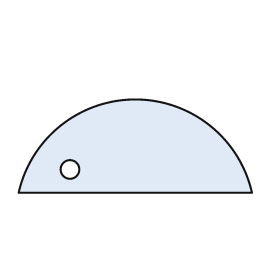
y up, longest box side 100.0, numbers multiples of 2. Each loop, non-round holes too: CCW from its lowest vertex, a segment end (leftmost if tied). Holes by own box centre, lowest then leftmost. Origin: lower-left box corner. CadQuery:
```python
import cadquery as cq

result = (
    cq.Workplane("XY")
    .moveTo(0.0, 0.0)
    .lineTo(100.0, 0.0)
    .threePointArc((50.0, 40.0), (0.0, 0.0))
    .close()
    .moveTo(22.0, 10.0)
    .circle(4.0)
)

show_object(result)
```